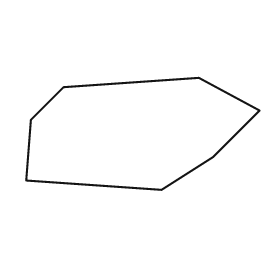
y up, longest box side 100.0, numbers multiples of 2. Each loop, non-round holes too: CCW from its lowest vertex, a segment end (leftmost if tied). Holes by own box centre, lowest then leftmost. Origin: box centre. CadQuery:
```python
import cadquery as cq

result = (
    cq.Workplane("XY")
    .moveTo(8.0, -24.0)
    .lineTo(30.0, -10.0)
    .lineTo(50.0, 10.0)
    .lineTo(24.0, 24.0)
    .lineTo(-34.0, 20.0)
    .lineTo(-48.0, 6.0)
    .lineTo(-50.0, -20.0)
    .close()
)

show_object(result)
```